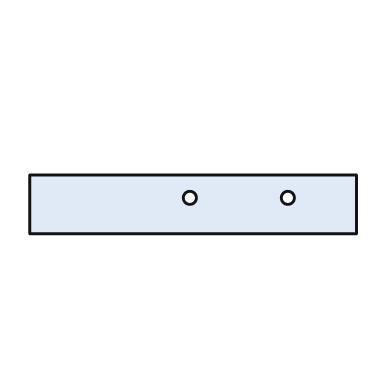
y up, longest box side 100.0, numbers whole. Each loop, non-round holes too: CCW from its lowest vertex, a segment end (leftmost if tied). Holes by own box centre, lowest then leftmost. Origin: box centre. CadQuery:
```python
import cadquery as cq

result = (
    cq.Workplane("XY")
    .moveTo(-50.0, -9.0)
    .lineTo(50.0, -9.0)
    .lineTo(50.0, 9.0)
    .lineTo(-50.0, 9.0)
    .close()
    .moveTo(-1.0, 2.0)
    .circle(2.0)
    .moveTo(29.0, 2.0)
    .circle(2.0)
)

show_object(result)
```